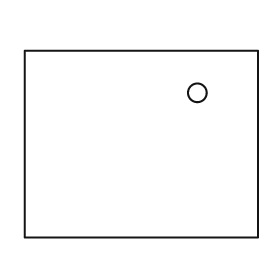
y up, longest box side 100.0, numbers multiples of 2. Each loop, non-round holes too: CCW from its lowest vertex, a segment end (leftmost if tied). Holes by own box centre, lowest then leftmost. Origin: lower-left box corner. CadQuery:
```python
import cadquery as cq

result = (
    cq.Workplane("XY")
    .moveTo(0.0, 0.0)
    .lineTo(100.0, 0.0)
    .lineTo(100.0, 80.0)
    .lineTo(0.0, 80.0)
    .close()
    .moveTo(74.0, 62.0)
    .circle(4.0)
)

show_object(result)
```